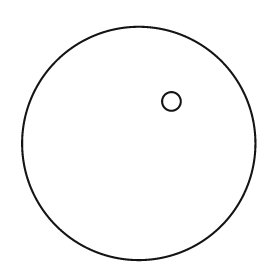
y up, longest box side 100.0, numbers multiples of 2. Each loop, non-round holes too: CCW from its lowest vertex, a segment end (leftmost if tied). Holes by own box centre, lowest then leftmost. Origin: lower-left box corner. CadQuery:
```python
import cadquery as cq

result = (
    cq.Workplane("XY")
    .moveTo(50.0, 50.0)
    .circle(50.0)
    .moveTo(64.0, 68.0)
    .circle(4.0)
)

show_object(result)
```